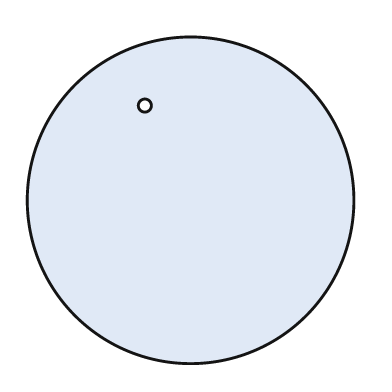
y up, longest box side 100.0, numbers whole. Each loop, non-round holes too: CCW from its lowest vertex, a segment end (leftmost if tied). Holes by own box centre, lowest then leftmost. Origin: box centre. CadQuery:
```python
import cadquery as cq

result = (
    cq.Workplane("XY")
    .moveTo(0.0, 0.0)
    .circle(50.0)
    .moveTo(-14.0, 29.0)
    .circle(2.0)
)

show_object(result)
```